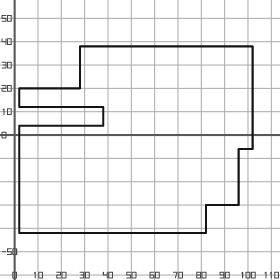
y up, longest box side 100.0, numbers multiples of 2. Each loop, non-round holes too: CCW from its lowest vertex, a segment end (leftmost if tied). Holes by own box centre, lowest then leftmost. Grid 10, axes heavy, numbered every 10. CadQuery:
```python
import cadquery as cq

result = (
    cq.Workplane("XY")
    .moveTo(2.0, -42.0)
    .lineTo(82.0, -42.0)
    .lineTo(82.0, -30.0)
    .lineTo(96.0, -30.0)
    .lineTo(96.0, -6.0)
    .lineTo(102.0, -6.0)
    .lineTo(102.0, 38.0)
    .lineTo(28.0, 38.0)
    .lineTo(28.0, 20.0)
    .lineTo(2.0, 20.0)
    .lineTo(2.0, 12.0)
    .lineTo(38.0, 12.0)
    .lineTo(38.0, 4.0)
    .lineTo(2.0, 4.0)
    .close()
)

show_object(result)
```